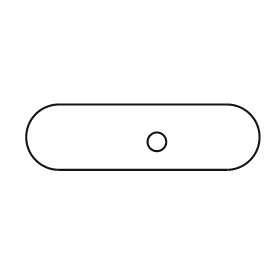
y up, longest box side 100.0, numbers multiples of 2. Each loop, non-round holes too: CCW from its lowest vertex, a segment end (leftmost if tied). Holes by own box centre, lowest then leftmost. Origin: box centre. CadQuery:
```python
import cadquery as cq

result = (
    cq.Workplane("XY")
    .moveTo(-36.0, -14.0)
    .lineTo(36.0, -14.0)
    .threePointArc((50.0, 0.0), (36.0, 14.0))
    .lineTo(-36.0, 14.0)
    .threePointArc((-50.0, 0.0), (-36.0, -14.0))
    .close()
    .moveTo(6.0, -2.0)
    .circle(4.0)
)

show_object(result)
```